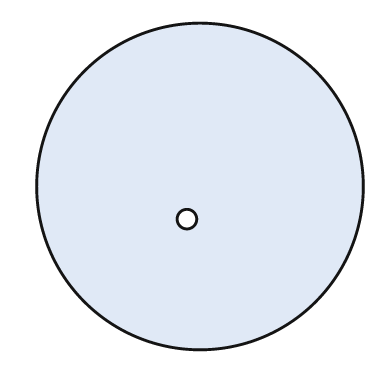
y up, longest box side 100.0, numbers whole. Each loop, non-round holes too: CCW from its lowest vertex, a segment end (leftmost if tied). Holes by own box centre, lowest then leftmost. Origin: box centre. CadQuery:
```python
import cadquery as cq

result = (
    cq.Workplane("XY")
    .moveTo(0.0, 0.0)
    .circle(50.0)
    .moveTo(-4.0, -10.0)
    .circle(3.0)
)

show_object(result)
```